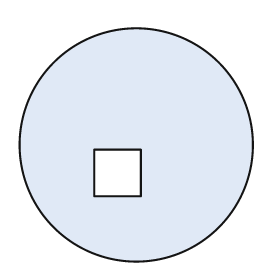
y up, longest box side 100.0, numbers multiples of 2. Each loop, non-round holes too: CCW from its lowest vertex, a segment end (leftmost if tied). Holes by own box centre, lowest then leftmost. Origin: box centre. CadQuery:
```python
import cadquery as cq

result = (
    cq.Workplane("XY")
    .moveTo(0.0, 0.0)
    .circle(50.0)
    .moveTo(-18.0, -22.0)
    .lineTo(2.0, -22.0)
    .lineTo(2.0, -2.0)
    .lineTo(-18.0, -2.0)
    .close()
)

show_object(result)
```